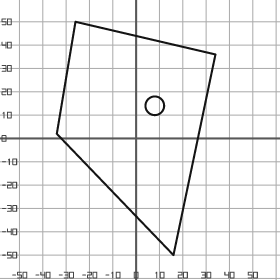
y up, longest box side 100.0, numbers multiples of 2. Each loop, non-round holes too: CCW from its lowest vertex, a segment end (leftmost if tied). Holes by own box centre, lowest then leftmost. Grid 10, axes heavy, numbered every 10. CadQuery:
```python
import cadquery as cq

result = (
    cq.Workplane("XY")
    .moveTo(16.0, -50.0)
    .lineTo(34.0, 36.0)
    .lineTo(-26.0, 50.0)
    .lineTo(-34.0, 2.0)
    .close()
    .moveTo(8.0, 14.0)
    .circle(4.0)
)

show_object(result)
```